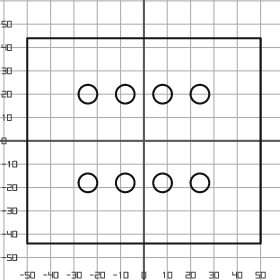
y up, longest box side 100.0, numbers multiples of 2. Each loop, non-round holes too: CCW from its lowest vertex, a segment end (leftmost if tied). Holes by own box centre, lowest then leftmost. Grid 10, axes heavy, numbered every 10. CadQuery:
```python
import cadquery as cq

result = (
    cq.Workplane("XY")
    .moveTo(-50.0, -44.0)
    .lineTo(50.0, -44.0)
    .lineTo(50.0, 44.0)
    .lineTo(-50.0, 44.0)
    .close()
    .moveTo(-24.0, -18.0)
    .circle(4.0)
    .moveTo(-8.0, -18.0)
    .circle(4.0)
    .moveTo(8.0, -18.0)
    .circle(4.0)
    .moveTo(24.0, -18.0)
    .circle(4.0)
    .moveTo(-24.0, 20.0)
    .circle(4.0)
    .moveTo(-8.0, 20.0)
    .circle(4.0)
    .moveTo(8.0, 20.0)
    .circle(4.0)
    .moveTo(24.0, 20.0)
    .circle(4.0)
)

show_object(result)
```